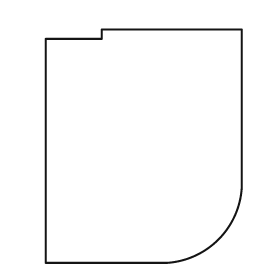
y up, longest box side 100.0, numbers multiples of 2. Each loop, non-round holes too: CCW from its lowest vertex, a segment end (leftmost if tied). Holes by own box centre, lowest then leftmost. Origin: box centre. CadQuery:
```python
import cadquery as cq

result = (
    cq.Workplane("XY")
    .moveTo(-42.0, -50.0)
    .lineTo(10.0, -50.0)
    .threePointArc((32.0, -40.0), (42.0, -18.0))
    .lineTo(42.0, 50.0)
    .lineTo(-18.0, 50.0)
    .lineTo(-18.0, 46.0)
    .lineTo(-42.0, 46.0)
    .close()
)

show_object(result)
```